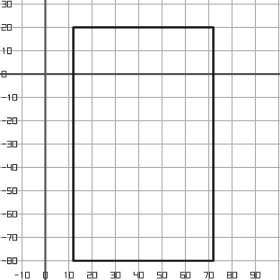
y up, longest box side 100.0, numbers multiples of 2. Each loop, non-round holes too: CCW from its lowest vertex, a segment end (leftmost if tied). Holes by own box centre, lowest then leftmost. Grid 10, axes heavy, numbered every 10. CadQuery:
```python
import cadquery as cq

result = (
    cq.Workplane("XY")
    .moveTo(12.0, -80.0)
    .lineTo(72.0, -80.0)
    .lineTo(72.0, 20.0)
    .lineTo(12.0, 20.0)
    .close()
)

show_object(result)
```